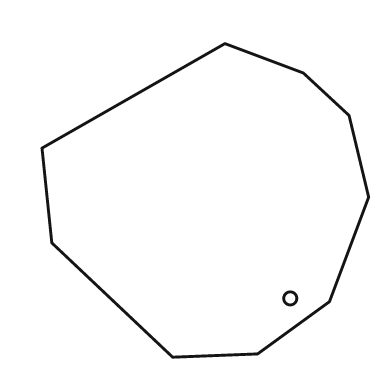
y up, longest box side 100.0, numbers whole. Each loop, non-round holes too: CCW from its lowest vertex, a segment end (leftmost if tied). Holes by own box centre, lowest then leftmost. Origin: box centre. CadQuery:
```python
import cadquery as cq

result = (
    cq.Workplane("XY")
    .moveTo(-10.0, -48.0)
    .lineTo(16.0, -47.0)
    .lineTo(38.0, -31.0)
    .lineTo(50.0, 1.0)
    .lineTo(44.0, 26.0)
    .lineTo(30.0, 39.0)
    .lineTo(6.0, 48.0)
    .lineTo(-50.0, 16.0)
    .lineTo(-47.0, -13.0)
    .close()
    .moveTo(26.0, -30.0)
    .circle(2.0)
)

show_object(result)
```